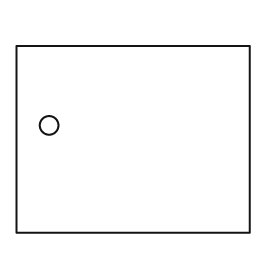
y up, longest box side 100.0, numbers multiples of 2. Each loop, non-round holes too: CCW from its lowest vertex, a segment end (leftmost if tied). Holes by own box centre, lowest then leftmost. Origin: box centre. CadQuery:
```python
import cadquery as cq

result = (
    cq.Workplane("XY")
    .moveTo(-50.0, -40.0)
    .lineTo(50.0, -40.0)
    .lineTo(50.0, 40.0)
    .lineTo(-50.0, 40.0)
    .close()
    .moveTo(-36.0, 6.0)
    .circle(4.0)
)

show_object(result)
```